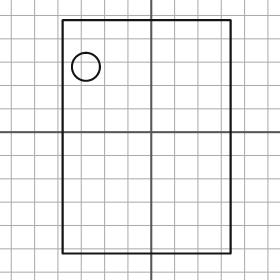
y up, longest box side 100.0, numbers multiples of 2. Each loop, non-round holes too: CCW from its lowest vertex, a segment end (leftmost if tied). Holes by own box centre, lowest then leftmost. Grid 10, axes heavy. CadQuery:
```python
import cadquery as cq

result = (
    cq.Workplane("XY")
    .moveTo(-38.0, -52.0)
    .lineTo(34.0, -52.0)
    .lineTo(34.0, 48.0)
    .lineTo(-38.0, 48.0)
    .close()
    .moveTo(-28.0, 28.0)
    .circle(6.0)
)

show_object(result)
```